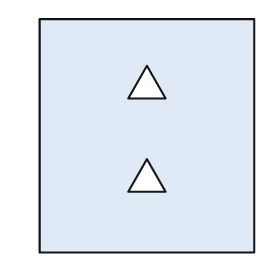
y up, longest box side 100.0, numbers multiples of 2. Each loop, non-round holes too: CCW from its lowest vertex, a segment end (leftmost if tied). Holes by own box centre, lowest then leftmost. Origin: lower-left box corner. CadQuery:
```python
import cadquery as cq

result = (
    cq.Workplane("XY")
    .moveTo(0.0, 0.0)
    .lineTo(92.0, 0.0)
    .lineTo(92.0, 100.0)
    .lineTo(0.0, 100.0)
    .close()
    .moveTo(38.0, 26.0)
    .lineTo(54.0, 26.0)
    .lineTo(46.0, 40.0)
    .close()
    .moveTo(38.0, 66.0)
    .lineTo(54.0, 66.0)
    .lineTo(46.0, 80.0)
    .close()
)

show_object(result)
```